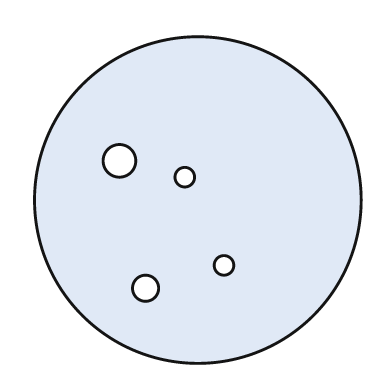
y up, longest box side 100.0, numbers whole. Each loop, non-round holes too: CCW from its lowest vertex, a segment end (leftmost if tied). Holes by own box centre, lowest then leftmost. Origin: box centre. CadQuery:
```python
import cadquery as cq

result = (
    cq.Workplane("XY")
    .moveTo(0.0, 0.0)
    .circle(50.0)
    .moveTo(-16.0, -27.0)
    .circle(4.0)
    .moveTo(8.0, -20.0)
    .circle(3.0)
    .moveTo(-4.0, 7.0)
    .circle(3.0)
    .moveTo(-24.0, 12.0)
    .circle(5.0)
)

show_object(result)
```